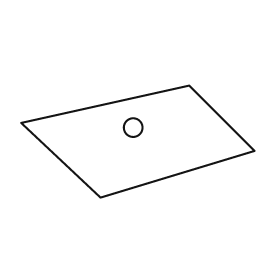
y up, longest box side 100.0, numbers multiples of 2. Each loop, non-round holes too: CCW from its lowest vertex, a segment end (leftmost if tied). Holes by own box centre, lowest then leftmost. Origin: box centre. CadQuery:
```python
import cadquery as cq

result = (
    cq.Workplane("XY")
    .moveTo(-16.0, -24.0)
    .lineTo(50.0, -4.0)
    .lineTo(22.0, 24.0)
    .lineTo(-50.0, 8.0)
    .close()
    .moveTo(-2.0, 6.0)
    .circle(4.0)
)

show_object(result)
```